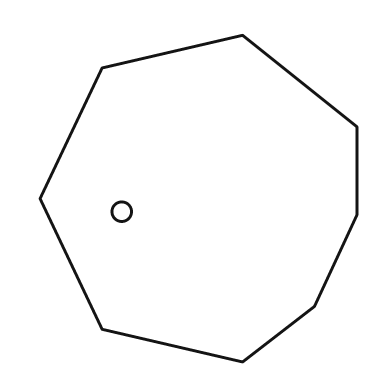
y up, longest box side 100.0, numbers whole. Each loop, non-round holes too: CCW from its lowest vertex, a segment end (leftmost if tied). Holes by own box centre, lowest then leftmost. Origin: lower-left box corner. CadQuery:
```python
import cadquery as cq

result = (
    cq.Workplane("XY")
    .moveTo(62.0, 0.0)
    .lineTo(84.0, 17.0)
    .lineTo(97.0, 45.0)
    .lineTo(97.0, 72.0)
    .lineTo(62.0, 100.0)
    .lineTo(19.0, 90.0)
    .lineTo(0.0, 50.0)
    .lineTo(19.0, 10.0)
    .close()
    .moveTo(25.0, 46.0)
    .circle(3.0)
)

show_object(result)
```